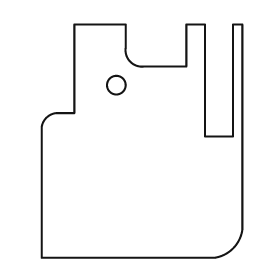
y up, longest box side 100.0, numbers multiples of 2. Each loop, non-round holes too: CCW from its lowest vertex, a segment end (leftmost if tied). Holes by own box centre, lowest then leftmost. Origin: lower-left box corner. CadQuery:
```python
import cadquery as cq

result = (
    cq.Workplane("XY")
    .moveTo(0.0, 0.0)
    .lineTo(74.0, 0.0)
    .threePointArc((82.0, 4.0), (86.0, 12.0))
    .lineTo(86.0, 100.0)
    .lineTo(82.0, 100.0)
    .lineTo(82.0, 52.0)
    .lineTo(70.0, 52.0)
    .lineTo(70.0, 100.0)
    .lineTo(62.0, 100.0)
    .lineTo(62.0, 82.0)
    .lineTo(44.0, 82.0)
    .threePointArc((38.0, 84.0), (36.0, 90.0))
    .lineTo(36.0, 100.0)
    .lineTo(14.0, 100.0)
    .lineTo(14.0, 62.0)
    .lineTo(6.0, 62.0)
    .threePointArc((2.0, 60.0), (0.0, 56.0))
    .close()
    .moveTo(32.0, 74.0)
    .circle(4.0)
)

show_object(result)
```